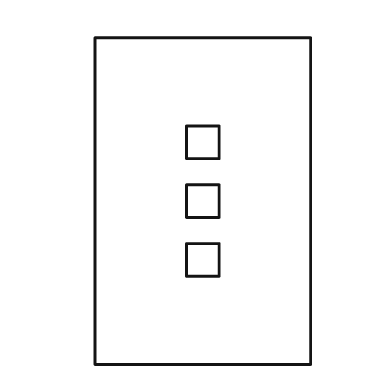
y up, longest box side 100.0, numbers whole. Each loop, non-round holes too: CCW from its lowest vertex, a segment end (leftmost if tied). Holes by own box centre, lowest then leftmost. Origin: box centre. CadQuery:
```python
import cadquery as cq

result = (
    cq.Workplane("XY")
    .moveTo(-33.0, -50.0)
    .lineTo(33.0, -50.0)
    .lineTo(33.0, 50.0)
    .lineTo(-33.0, 50.0)
    .close()
    .moveTo(-5.0, -23.0)
    .lineTo(5.0, -23.0)
    .lineTo(5.0, -13.0)
    .lineTo(-5.0, -13.0)
    .close()
    .moveTo(-5.0, -5.0)
    .lineTo(5.0, -5.0)
    .lineTo(5.0, 5.0)
    .lineTo(-5.0, 5.0)
    .close()
    .moveTo(-5.0, 13.0)
    .lineTo(5.0, 13.0)
    .lineTo(5.0, 23.0)
    .lineTo(-5.0, 23.0)
    .close()
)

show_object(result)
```